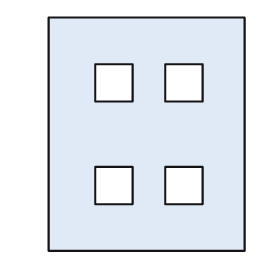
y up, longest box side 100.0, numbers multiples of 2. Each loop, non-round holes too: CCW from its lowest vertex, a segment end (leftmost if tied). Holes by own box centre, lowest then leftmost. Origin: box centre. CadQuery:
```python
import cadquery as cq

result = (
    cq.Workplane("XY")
    .moveTo(-42.0, -50.0)
    .lineTo(42.0, -50.0)
    .lineTo(42.0, 50.0)
    .lineTo(-42.0, 50.0)
    .close()
    .moveTo(-22.0, -30.0)
    .lineTo(-6.0, -30.0)
    .lineTo(-6.0, -14.0)
    .lineTo(-22.0, -14.0)
    .close()
    .moveTo(8.0, -30.0)
    .lineTo(24.0, -30.0)
    .lineTo(24.0, -14.0)
    .lineTo(8.0, -14.0)
    .close()
    .moveTo(-22.0, 14.0)
    .lineTo(-6.0, 14.0)
    .lineTo(-6.0, 30.0)
    .lineTo(-22.0, 30.0)
    .close()
    .moveTo(8.0, 14.0)
    .lineTo(24.0, 14.0)
    .lineTo(24.0, 30.0)
    .lineTo(8.0, 30.0)
    .close()
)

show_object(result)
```